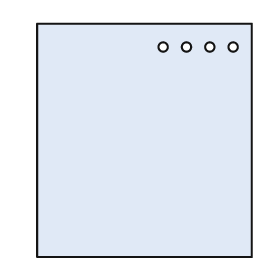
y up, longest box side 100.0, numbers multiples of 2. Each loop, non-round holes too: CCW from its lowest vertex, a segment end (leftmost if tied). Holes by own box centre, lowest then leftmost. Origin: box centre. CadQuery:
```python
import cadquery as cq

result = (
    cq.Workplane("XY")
    .moveTo(-46.0, -50.0)
    .lineTo(46.0, -50.0)
    .lineTo(46.0, 50.0)
    .lineTo(-46.0, 50.0)
    .close()
    .moveTo(8.0, 40.0)
    .circle(2.0)
    .moveTo(18.0, 40.0)
    .circle(2.0)
    .moveTo(28.0, 40.0)
    .circle(2.0)
    .moveTo(38.0, 40.0)
    .circle(2.0)
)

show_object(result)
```